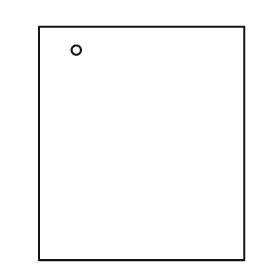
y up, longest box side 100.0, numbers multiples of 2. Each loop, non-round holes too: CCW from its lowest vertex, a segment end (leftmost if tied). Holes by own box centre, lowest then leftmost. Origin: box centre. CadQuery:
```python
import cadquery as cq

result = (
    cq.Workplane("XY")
    .moveTo(-44.0, -50.0)
    .lineTo(44.0, -50.0)
    .lineTo(44.0, 50.0)
    .lineTo(-44.0, 50.0)
    .close()
    .moveTo(-28.0, 40.0)
    .circle(2.0)
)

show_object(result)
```